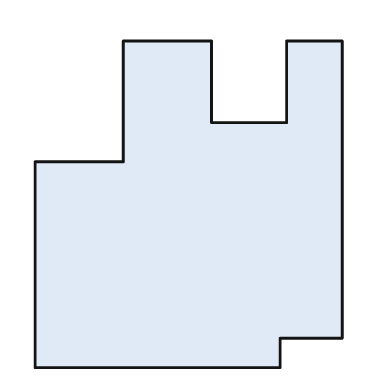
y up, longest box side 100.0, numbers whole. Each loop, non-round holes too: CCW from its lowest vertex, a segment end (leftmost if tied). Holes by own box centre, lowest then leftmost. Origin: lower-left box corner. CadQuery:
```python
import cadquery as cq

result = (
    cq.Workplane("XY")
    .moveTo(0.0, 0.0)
    .lineTo(75.0, 0.0)
    .lineTo(75.0, 9.0)
    .lineTo(94.0, 9.0)
    .lineTo(94.0, 100.0)
    .lineTo(77.0, 100.0)
    .lineTo(77.0, 75.0)
    .lineTo(54.0, 75.0)
    .lineTo(54.0, 100.0)
    .lineTo(27.0, 100.0)
    .lineTo(27.0, 63.0)
    .lineTo(0.0, 63.0)
    .close()
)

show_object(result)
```